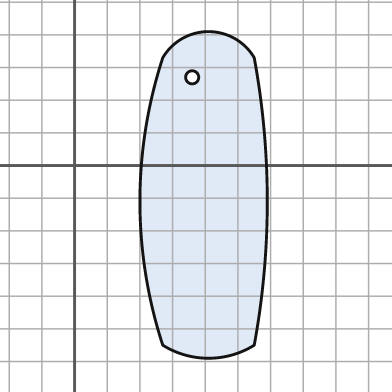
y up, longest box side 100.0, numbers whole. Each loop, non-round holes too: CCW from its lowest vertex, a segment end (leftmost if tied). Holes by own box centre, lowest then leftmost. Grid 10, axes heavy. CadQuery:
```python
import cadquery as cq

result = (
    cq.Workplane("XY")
    .moveTo(27.0, -55.0)
    .threePointArc((41.0, -59.0), (55.0, -55.0))
    .threePointArc((59.0, -11.0), (55.0, 33.0))
    .threePointArc((41.0, 41.0), (27.0, 33.0))
    .threePointArc((20.0, -11.0), (27.0, -55.0))
    .close()
    .moveTo(36.0, 27.0)
    .circle(2.0)
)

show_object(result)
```